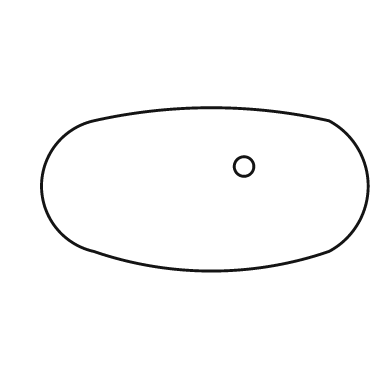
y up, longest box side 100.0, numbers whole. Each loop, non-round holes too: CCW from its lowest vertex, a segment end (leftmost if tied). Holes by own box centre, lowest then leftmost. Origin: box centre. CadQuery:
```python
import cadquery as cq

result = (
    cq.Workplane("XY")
    .moveTo(-34.0, -19.0)
    .threePointArc((2.0, -25.0), (38.0, -19.0))
    .threePointArc((50.0, 1.0), (38.0, 21.0))
    .threePointArc((2.0, 25.0), (-34.0, 21.0))
    .threePointArc((-50.0, 1.0), (-34.0, -19.0))
    .close()
    .moveTo(12.0, 7.0)
    .circle(3.0)
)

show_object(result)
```